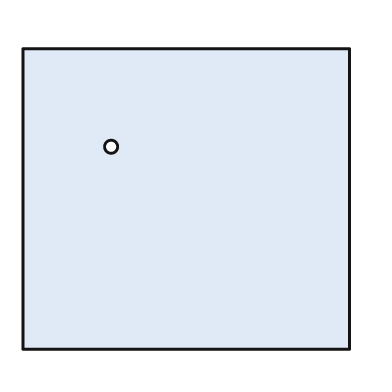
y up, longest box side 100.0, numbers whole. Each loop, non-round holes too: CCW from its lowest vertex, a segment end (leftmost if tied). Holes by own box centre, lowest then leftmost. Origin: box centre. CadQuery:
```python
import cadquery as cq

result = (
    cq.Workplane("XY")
    .moveTo(-50.0, -46.0)
    .lineTo(50.0, -46.0)
    .lineTo(50.0, 46.0)
    .lineTo(-50.0, 46.0)
    .close()
    .moveTo(-23.0, 16.0)
    .circle(2.0)
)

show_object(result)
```